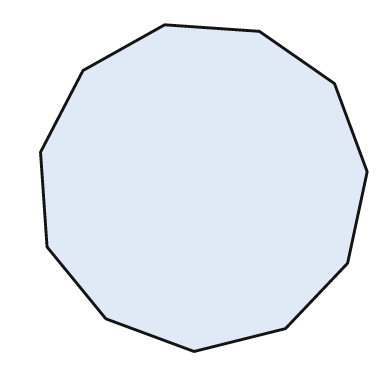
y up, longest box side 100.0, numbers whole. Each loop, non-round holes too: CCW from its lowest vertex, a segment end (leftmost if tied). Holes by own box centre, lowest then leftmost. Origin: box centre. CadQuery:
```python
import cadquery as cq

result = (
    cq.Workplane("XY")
    .moveTo(-3.0, -50.0)
    .lineTo(25.0, -43.0)
    .lineTo(44.0, -23.0)
    .lineTo(50.0, 5.0)
    .lineTo(40.0, 32.0)
    .lineTo(17.0, 48.0)
    .lineTo(-12.0, 50.0)
    .lineTo(-37.0, 36.0)
    .lineTo(-50.0, 11.0)
    .lineTo(-48.0, -18.0)
    .lineTo(-30.0, -40.0)
    .close()
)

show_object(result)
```